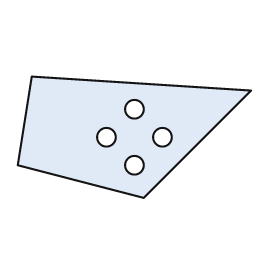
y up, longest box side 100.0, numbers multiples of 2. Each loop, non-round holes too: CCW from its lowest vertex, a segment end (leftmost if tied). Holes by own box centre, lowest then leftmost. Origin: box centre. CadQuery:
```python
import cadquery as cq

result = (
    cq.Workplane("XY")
    .moveTo(4.0, -26.0)
    .lineTo(50.0, 20.0)
    .lineTo(-44.0, 26.0)
    .lineTo(-50.0, -12.0)
    .close()
    .moveTo(0.0, -12.0)
    .circle(4.0)
    .moveTo(-12.0, 0.0)
    .circle(4.0)
    .moveTo(12.0, 0.0)
    .circle(4.0)
    .moveTo(0.0, 12.0)
    .circle(4.0)
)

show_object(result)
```